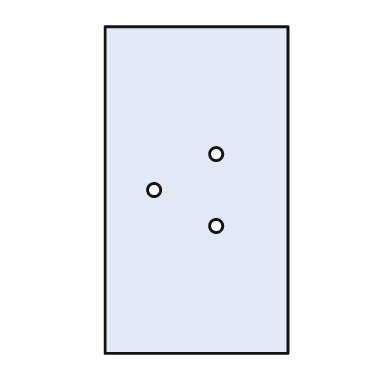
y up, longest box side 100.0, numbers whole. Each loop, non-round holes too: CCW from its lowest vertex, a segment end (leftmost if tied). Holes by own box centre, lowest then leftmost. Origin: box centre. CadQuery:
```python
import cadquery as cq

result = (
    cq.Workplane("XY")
    .moveTo(-28.0, -50.0)
    .lineTo(28.0, -50.0)
    .lineTo(28.0, 50.0)
    .lineTo(-28.0, 50.0)
    .close()
    .moveTo(6.0, -11.0)
    .circle(2.0)
    .moveTo(-13.0, 0.0)
    .circle(2.0)
    .moveTo(6.0, 11.0)
    .circle(2.0)
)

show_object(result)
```